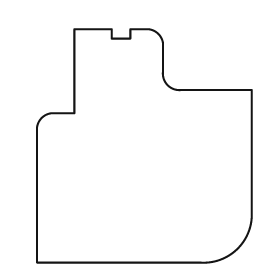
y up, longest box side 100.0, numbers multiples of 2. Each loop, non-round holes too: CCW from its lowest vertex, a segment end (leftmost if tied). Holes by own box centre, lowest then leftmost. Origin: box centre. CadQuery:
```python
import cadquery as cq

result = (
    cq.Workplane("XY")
    .moveTo(-46.0, -50.0)
    .lineTo(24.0, -50.0)
    .threePointArc((40.0, -44.0), (46.0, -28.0))
    .lineTo(46.0, 24.0)
    .lineTo(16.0, 24.0)
    .threePointArc((10.0, 26.0), (8.0, 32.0))
    .lineTo(8.0, 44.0)
    .threePointArc((6.0, 48.0), (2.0, 50.0))
    .lineTo(-6.0, 50.0)
    .lineTo(-6.0, 46.0)
    .lineTo(-14.0, 46.0)
    .lineTo(-14.0, 50.0)
    .lineTo(-30.0, 50.0)
    .lineTo(-30.0, 14.0)
    .lineTo(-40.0, 14.0)
    .threePointArc((-44.0, 12.0), (-46.0, 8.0))
    .close()
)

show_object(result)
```